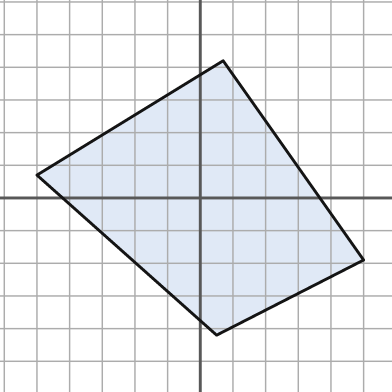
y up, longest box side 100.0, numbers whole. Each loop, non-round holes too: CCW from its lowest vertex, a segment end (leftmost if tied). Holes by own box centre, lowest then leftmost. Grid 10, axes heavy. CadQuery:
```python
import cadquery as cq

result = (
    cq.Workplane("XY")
    .moveTo(5.0, -42.0)
    .lineTo(50.0, -19.0)
    .lineTo(7.0, 42.0)
    .lineTo(-50.0, 7.0)
    .close()
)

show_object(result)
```